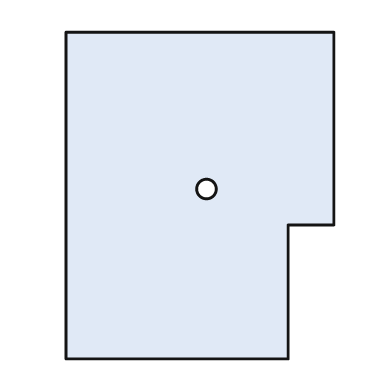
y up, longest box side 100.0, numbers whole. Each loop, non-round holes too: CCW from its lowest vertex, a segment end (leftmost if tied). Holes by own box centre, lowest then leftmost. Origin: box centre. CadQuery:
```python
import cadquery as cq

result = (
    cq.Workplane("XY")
    .moveTo(-41.0, -50.0)
    .lineTo(27.0, -50.0)
    .lineTo(27.0, -9.0)
    .lineTo(41.0, -9.0)
    .lineTo(41.0, 50.0)
    .lineTo(-41.0, 50.0)
    .close()
    .moveTo(2.0, 2.0)
    .circle(3.0)
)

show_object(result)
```